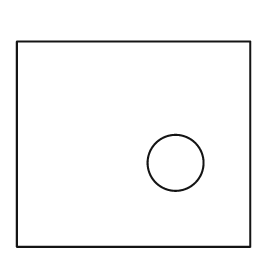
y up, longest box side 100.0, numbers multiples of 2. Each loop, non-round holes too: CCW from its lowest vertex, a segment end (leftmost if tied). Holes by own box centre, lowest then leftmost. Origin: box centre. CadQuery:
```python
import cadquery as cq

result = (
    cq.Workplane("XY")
    .moveTo(-50.0, -44.0)
    .lineTo(50.0, -44.0)
    .lineTo(50.0, 44.0)
    .lineTo(-50.0, 44.0)
    .close()
    .moveTo(18.0, -8.0)
    .circle(12.0)
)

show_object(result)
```